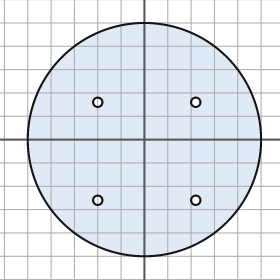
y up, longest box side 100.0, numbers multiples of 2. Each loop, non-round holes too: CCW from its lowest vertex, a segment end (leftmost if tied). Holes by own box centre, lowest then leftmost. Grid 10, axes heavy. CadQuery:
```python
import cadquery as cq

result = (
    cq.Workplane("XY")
    .moveTo(0.0, 0.0)
    .circle(50.0)
    .moveTo(-20.0, -26.0)
    .circle(2.0)
    .moveTo(22.0, -26.0)
    .circle(2.0)
    .moveTo(-20.0, 16.0)
    .circle(2.0)
    .moveTo(22.0, 16.0)
    .circle(2.0)
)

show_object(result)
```